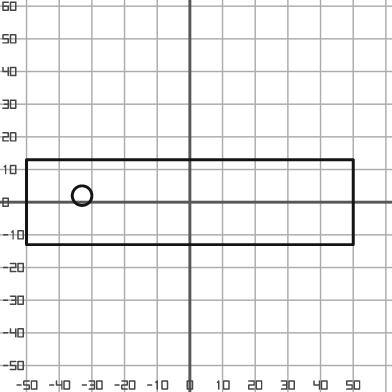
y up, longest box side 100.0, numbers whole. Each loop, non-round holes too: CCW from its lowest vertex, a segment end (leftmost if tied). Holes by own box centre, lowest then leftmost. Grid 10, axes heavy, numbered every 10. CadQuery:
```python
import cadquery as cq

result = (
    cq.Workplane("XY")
    .moveTo(-50.0, -13.0)
    .lineTo(50.0, -13.0)
    .lineTo(50.0, 13.0)
    .lineTo(-50.0, 13.0)
    .close()
    .moveTo(-33.0, 2.0)
    .circle(3.0)
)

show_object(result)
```